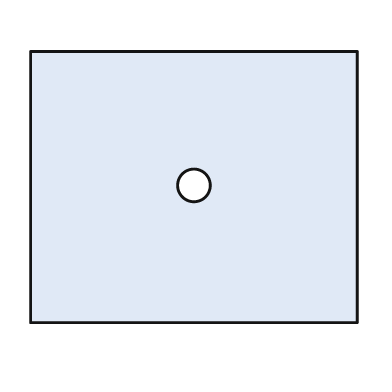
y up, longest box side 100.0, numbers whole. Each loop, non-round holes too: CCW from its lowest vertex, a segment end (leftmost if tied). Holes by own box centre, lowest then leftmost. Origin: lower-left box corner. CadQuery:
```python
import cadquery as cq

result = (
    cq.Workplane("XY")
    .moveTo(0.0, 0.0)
    .lineTo(100.0, 0.0)
    .lineTo(100.0, 83.0)
    .lineTo(0.0, 83.0)
    .close()
    .moveTo(50.0, 42.0)
    .circle(5.0)
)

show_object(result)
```